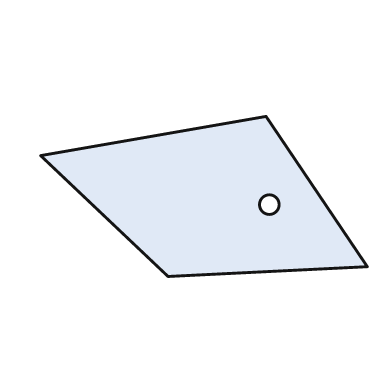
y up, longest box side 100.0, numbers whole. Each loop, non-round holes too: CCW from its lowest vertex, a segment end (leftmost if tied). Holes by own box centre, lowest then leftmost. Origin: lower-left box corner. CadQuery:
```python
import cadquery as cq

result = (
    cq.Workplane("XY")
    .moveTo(39.0, 0.0)
    .lineTo(100.0, 3.0)
    .lineTo(69.0, 49.0)
    .lineTo(0.0, 37.0)
    .close()
    .moveTo(70.0, 22.0)
    .circle(3.0)
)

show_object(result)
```